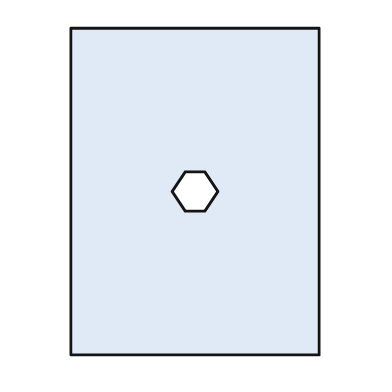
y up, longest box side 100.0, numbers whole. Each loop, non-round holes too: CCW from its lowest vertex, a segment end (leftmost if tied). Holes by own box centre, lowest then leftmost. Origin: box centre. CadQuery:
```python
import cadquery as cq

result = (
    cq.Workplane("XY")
    .moveTo(-38.0, -50.0)
    .lineTo(38.0, -50.0)
    .lineTo(38.0, 50.0)
    .lineTo(-38.0, 50.0)
    .close()
    .moveTo(-3.0, -6.0)
    .lineTo(3.0, -6.0)
    .lineTo(7.0, 0.0)
    .lineTo(3.0, 6.0)
    .lineTo(-3.0, 6.0)
    .lineTo(-7.0, 0.0)
    .close()
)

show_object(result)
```